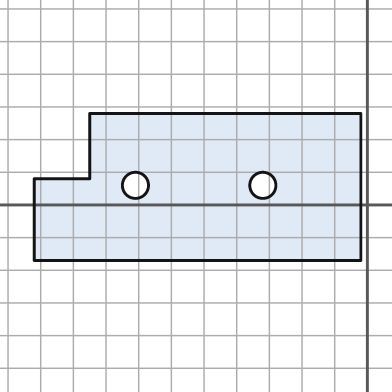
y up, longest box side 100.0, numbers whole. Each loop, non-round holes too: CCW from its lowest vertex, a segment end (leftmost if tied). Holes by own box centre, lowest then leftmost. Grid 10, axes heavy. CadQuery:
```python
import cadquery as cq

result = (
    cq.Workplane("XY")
    .moveTo(-102.0, -17.0)
    .lineTo(-2.0, -17.0)
    .lineTo(-2.0, 28.0)
    .lineTo(-85.0, 28.0)
    .lineTo(-85.0, 8.0)
    .lineTo(-102.0, 8.0)
    .close()
    .moveTo(-71.0, 6.0)
    .circle(4.0)
    .moveTo(-32.0, 6.0)
    .circle(4.0)
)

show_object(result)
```